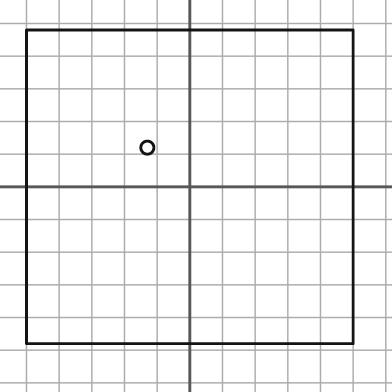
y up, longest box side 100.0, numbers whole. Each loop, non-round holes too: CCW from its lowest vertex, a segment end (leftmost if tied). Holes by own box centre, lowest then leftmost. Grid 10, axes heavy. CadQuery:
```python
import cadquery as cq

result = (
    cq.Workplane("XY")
    .moveTo(-50.0, -48.0)
    .lineTo(50.0, -48.0)
    .lineTo(50.0, 48.0)
    .lineTo(-50.0, 48.0)
    .close()
    .moveTo(-13.0, 12.0)
    .circle(2.0)
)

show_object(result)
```